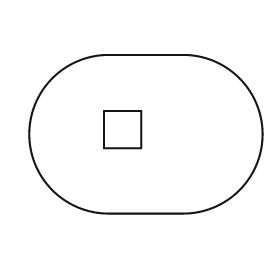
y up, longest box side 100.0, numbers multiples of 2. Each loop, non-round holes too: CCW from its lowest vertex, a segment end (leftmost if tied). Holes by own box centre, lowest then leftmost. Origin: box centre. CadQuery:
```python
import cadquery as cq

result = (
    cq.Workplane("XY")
    .moveTo(-16.0, -34.0)
    .lineTo(16.0, -34.0)
    .threePointArc((50.0, 0.0), (16.0, 34.0))
    .lineTo(-16.0, 34.0)
    .threePointArc((-50.0, 0.0), (-16.0, -34.0))
    .close()
    .moveTo(-18.0, -6.0)
    .lineTo(-2.0, -6.0)
    .lineTo(-2.0, 10.0)
    .lineTo(-18.0, 10.0)
    .close()
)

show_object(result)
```